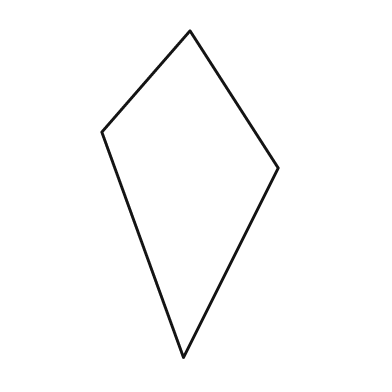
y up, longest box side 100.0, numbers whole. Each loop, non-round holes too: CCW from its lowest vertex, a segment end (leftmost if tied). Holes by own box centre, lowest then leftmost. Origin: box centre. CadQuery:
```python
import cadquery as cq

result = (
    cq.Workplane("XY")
    .moveTo(-2.0, -50.0)
    .lineTo(27.0, 8.0)
    .lineTo(0.0, 50.0)
    .lineTo(-27.0, 19.0)
    .close()
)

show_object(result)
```